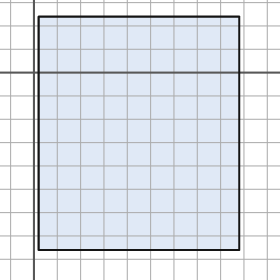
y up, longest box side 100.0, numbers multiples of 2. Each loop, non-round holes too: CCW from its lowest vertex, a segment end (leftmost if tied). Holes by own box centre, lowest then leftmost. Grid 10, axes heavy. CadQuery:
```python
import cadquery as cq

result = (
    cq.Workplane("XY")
    .moveTo(2.0, -76.0)
    .lineTo(88.0, -76.0)
    .lineTo(88.0, 24.0)
    .lineTo(2.0, 24.0)
    .close()
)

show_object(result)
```